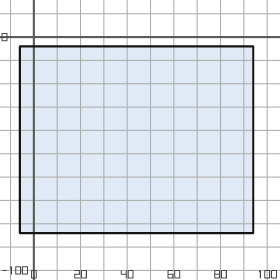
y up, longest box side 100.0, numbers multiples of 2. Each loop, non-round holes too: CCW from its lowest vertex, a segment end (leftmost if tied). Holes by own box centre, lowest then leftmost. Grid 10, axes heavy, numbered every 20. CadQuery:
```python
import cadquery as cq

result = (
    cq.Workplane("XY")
    .moveTo(-6.0, -84.0)
    .lineTo(94.0, -84.0)
    .lineTo(94.0, -4.0)
    .lineTo(-6.0, -4.0)
    .close()
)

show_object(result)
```